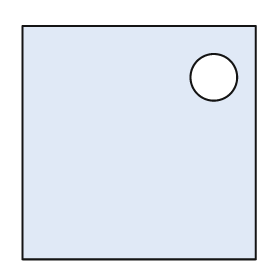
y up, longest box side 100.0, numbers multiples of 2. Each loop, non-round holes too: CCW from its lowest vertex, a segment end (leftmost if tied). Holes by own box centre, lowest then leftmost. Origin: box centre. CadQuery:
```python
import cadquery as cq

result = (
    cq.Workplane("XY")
    .moveTo(-50.0, -50.0)
    .lineTo(50.0, -50.0)
    .lineTo(50.0, 50.0)
    .lineTo(-50.0, 50.0)
    .close()
    .moveTo(32.0, 28.0)
    .circle(10.0)
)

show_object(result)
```